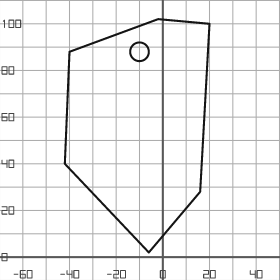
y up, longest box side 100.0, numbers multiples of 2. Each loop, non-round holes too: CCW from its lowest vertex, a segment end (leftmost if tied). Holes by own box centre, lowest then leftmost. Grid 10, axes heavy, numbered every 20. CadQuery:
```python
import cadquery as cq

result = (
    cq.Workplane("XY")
    .moveTo(-6.0, 2.0)
    .lineTo(16.0, 28.0)
    .lineTo(20.0, 100.0)
    .lineTo(-2.0, 102.0)
    .lineTo(-40.0, 88.0)
    .lineTo(-42.0, 40.0)
    .close()
    .moveTo(-10.0, 88.0)
    .circle(4.0)
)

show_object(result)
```